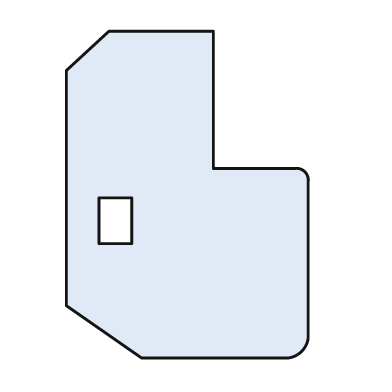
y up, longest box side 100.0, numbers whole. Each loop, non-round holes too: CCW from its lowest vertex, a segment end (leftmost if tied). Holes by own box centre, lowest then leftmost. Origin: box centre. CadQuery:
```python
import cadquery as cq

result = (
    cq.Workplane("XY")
    .moveTo(-14.0, -50.0)
    .lineTo(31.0, -50.0)
    .threePointArc((35.0, -48.0), (37.0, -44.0))
    .lineTo(37.0, 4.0)
    .threePointArc((36.0, 7.0), (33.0, 8.0))
    .lineTo(8.0, 8.0)
    .lineTo(8.0, 50.0)
    .lineTo(-24.0, 50.0)
    .lineTo(-37.0, 38.0)
    .lineTo(-37.0, -34.0)
    .close()
    .moveTo(-27.0, -15.0)
    .lineTo(-17.0, -15.0)
    .lineTo(-17.0, -1.0)
    .lineTo(-27.0, -1.0)
    .close()
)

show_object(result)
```